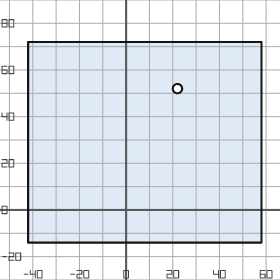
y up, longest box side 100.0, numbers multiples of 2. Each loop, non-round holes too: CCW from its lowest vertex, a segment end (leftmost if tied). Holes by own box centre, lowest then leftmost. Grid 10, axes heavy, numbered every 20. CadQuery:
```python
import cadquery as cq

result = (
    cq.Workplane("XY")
    .moveTo(-42.0, -14.0)
    .lineTo(58.0, -14.0)
    .lineTo(58.0, 72.0)
    .lineTo(-42.0, 72.0)
    .close()
    .moveTo(22.0, 52.0)
    .circle(2.0)
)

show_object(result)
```